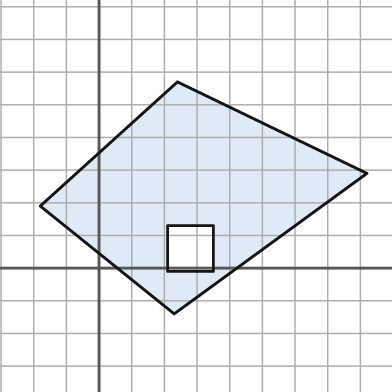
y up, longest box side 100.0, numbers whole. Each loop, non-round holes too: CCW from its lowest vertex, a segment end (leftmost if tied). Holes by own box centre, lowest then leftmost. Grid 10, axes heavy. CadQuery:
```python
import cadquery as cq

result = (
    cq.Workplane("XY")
    .moveTo(23.0, -14.0)
    .lineTo(82.0, 29.0)
    .lineTo(24.0, 57.0)
    .lineTo(-18.0, 19.0)
    .close()
    .moveTo(21.0, -1.0)
    .lineTo(35.0, -1.0)
    .lineTo(35.0, 13.0)
    .lineTo(21.0, 13.0)
    .close()
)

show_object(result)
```